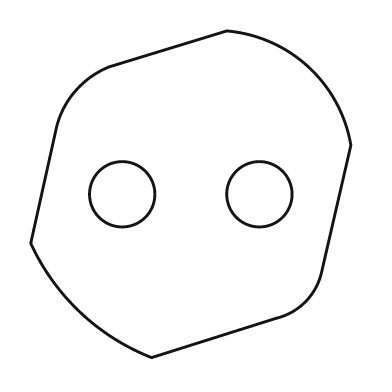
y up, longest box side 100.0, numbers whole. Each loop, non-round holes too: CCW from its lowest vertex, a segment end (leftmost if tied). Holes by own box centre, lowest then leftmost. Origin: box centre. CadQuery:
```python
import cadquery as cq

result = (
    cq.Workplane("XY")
    .moveTo(-12.0, -50.0)
    .lineTo(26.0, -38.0)
    .threePointArc((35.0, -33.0), (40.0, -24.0))
    .lineTo(49.0, 15.0)
    .threePointArc((36.0, 39.0), (11.0, 50.0))
    .lineTo(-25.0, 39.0)
    .threePointArc((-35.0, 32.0), (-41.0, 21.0))
    .lineTo(-49.0, -15.0)
    .threePointArc((-34.0, -36.0), (-12.0, -50.0))
    .close()
    .moveTo(-21.0, 0.0)
    .circle(10.0)
    .moveTo(21.0, 0.0)
    .circle(10.0)
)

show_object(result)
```